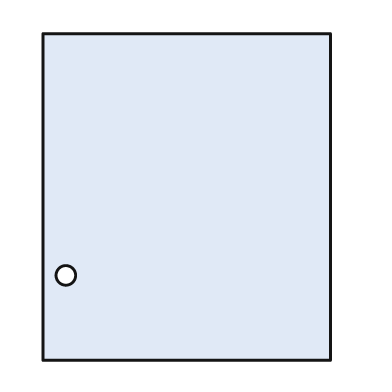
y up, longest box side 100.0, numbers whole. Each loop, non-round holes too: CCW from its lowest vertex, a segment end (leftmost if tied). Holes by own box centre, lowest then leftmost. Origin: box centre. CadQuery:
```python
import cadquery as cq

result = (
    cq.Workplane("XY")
    .moveTo(-44.0, -50.0)
    .lineTo(44.0, -50.0)
    .lineTo(44.0, 50.0)
    .lineTo(-44.0, 50.0)
    .close()
    .moveTo(-37.0, -24.0)
    .circle(3.0)
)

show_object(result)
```